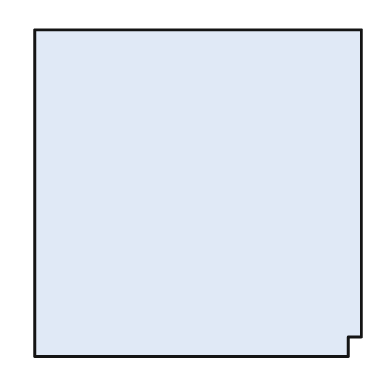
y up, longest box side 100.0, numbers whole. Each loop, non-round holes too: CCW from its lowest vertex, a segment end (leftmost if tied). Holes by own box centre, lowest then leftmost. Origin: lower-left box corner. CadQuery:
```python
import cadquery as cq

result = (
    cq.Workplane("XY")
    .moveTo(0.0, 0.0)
    .lineTo(96.0, 0.0)
    .lineTo(96.0, 6.0)
    .lineTo(100.0, 6.0)
    .lineTo(100.0, 100.0)
    .lineTo(0.0, 100.0)
    .close()
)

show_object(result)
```